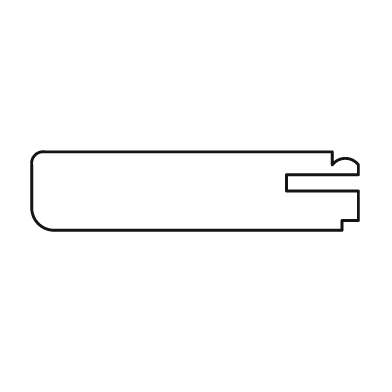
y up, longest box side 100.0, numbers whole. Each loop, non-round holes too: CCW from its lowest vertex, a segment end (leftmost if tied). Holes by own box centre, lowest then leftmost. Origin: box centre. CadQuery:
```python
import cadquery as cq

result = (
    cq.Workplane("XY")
    .moveTo(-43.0, -12.0)
    .lineTo(45.0, -12.0)
    .lineTo(45.0, -9.0)
    .lineTo(50.0, -9.0)
    .lineTo(50.0, 0.0)
    .lineTo(28.0, 0.0)
    .lineTo(28.0, 5.0)
    .lineTo(50.0, 5.0)
    .lineTo(50.0, 8.0)
    .threePointArc((46.0, 10.0), (42.0, 8.0))
    .lineTo(42.0, 12.0)
    .lineTo(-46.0, 12.0)
    .threePointArc((-49.0, 11.0), (-50.0, 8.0))
    .lineTo(-50.0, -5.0)
    .threePointArc((-48.0, -10.0), (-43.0, -12.0))
    .close()
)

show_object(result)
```